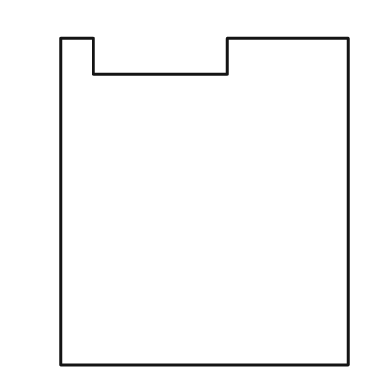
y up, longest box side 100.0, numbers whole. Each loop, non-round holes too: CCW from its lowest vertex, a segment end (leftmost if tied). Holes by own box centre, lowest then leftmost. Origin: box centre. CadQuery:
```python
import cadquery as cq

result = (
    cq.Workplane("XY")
    .moveTo(-44.0, -50.0)
    .lineTo(44.0, -50.0)
    .lineTo(44.0, 50.0)
    .lineTo(7.0, 50.0)
    .lineTo(7.0, 39.0)
    .lineTo(-34.0, 39.0)
    .lineTo(-34.0, 50.0)
    .lineTo(-44.0, 50.0)
    .close()
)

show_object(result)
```